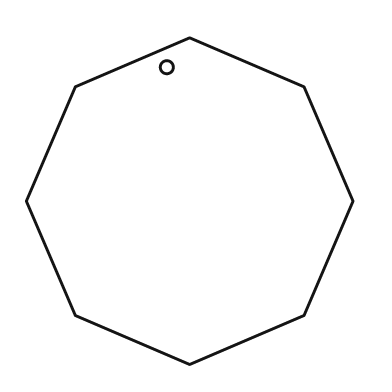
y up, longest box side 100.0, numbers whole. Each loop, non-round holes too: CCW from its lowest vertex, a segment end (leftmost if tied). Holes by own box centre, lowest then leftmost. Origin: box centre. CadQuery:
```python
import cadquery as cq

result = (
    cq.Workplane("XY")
    .moveTo(0.0, -50.0)
    .lineTo(35.0, -35.0)
    .lineTo(50.0, 0.0)
    .lineTo(35.0, 35.0)
    .lineTo(0.0, 50.0)
    .lineTo(-35.0, 35.0)
    .lineTo(-50.0, 0.0)
    .lineTo(-35.0, -35.0)
    .close()
    .moveTo(-7.0, 41.0)
    .circle(2.0)
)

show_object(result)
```